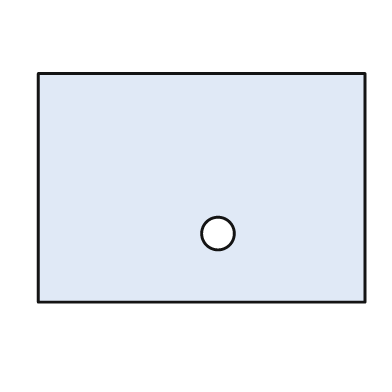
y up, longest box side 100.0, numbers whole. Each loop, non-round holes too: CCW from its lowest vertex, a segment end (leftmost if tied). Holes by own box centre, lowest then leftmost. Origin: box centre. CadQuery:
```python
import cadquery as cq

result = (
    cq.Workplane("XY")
    .moveTo(-50.0, -35.0)
    .lineTo(50.0, -35.0)
    .lineTo(50.0, 35.0)
    .lineTo(-50.0, 35.0)
    .close()
    .moveTo(5.0, -14.0)
    .circle(5.0)
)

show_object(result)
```